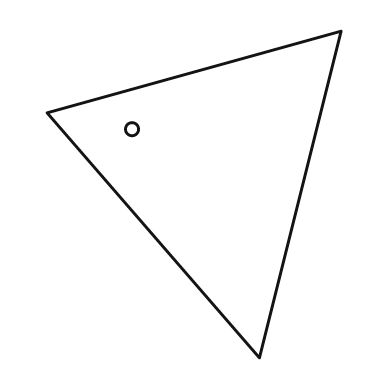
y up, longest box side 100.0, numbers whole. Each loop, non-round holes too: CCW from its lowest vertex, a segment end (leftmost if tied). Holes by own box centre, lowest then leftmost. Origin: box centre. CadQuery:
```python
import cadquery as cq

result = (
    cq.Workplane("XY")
    .moveTo(20.0, -50.0)
    .lineTo(45.0, 50.0)
    .lineTo(-45.0, 25.0)
    .close()
    .moveTo(-19.0, 20.0)
    .circle(2.0)
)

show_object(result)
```